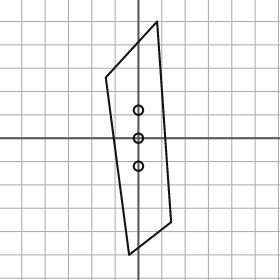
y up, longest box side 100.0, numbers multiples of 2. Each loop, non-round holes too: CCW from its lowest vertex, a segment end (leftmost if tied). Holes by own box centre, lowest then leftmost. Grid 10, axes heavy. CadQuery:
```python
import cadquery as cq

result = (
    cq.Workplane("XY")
    .moveTo(-4.0, -50.0)
    .lineTo(14.0, -36.0)
    .lineTo(8.0, 50.0)
    .lineTo(-14.0, 26.0)
    .close()
    .moveTo(0.0, -12.0)
    .circle(2.0)
    .moveTo(0.0, 0.0)
    .circle(2.0)
    .moveTo(0.0, 12.0)
    .circle(2.0)
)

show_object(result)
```